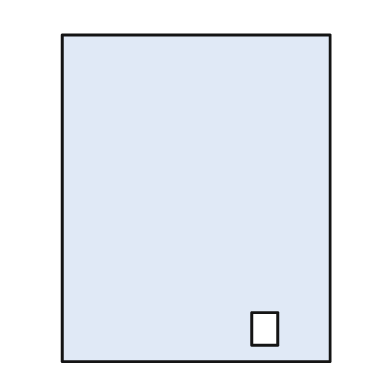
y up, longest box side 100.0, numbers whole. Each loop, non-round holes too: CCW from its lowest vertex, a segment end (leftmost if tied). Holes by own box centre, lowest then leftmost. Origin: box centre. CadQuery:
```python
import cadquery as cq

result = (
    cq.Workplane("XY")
    .moveTo(-41.0, -50.0)
    .lineTo(41.0, -50.0)
    .lineTo(41.0, 50.0)
    .lineTo(-41.0, 50.0)
    .close()
    .moveTo(17.0, -45.0)
    .lineTo(25.0, -45.0)
    .lineTo(25.0, -35.0)
    .lineTo(17.0, -35.0)
    .close()
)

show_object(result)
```